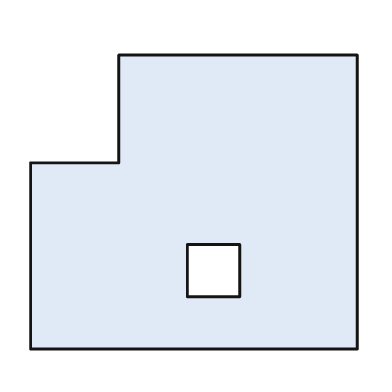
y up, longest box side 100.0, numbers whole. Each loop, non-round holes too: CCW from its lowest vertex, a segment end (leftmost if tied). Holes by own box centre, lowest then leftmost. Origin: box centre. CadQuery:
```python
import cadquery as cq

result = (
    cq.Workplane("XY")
    .moveTo(-50.0, -45.0)
    .lineTo(50.0, -45.0)
    .lineTo(50.0, 45.0)
    .lineTo(-23.0, 45.0)
    .lineTo(-23.0, 12.0)
    .lineTo(-50.0, 12.0)
    .close()
    .moveTo(-2.0, -29.0)
    .lineTo(14.0, -29.0)
    .lineTo(14.0, -13.0)
    .lineTo(-2.0, -13.0)
    .close()
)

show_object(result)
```